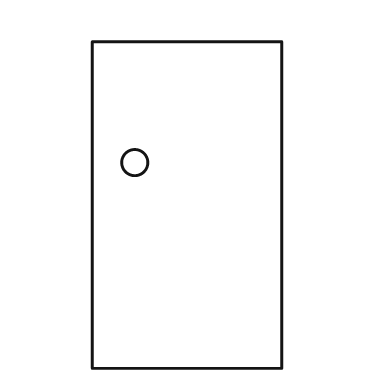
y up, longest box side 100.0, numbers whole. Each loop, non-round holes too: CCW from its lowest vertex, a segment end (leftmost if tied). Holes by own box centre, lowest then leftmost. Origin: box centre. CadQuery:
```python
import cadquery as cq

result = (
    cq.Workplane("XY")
    .moveTo(-29.0, -50.0)
    .lineTo(29.0, -50.0)
    .lineTo(29.0, 50.0)
    .lineTo(-29.0, 50.0)
    .close()
    .moveTo(-16.0, 13.0)
    .circle(4.0)
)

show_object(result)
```